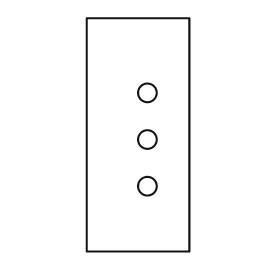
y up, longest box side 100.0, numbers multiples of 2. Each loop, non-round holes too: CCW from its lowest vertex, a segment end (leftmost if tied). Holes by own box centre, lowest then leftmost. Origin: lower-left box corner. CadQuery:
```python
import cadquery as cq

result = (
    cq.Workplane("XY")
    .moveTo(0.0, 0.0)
    .lineTo(44.0, 0.0)
    .lineTo(44.0, 100.0)
    .lineTo(0.0, 100.0)
    .close()
    .moveTo(26.0, 28.0)
    .circle(4.0)
    .moveTo(26.0, 48.0)
    .circle(4.0)
    .moveTo(26.0, 68.0)
    .circle(4.0)
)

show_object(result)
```